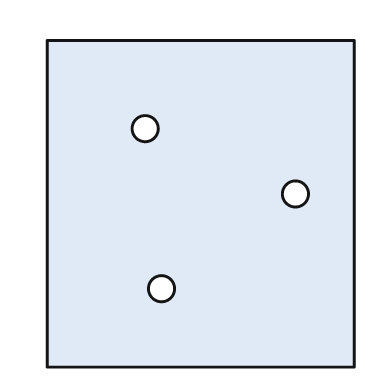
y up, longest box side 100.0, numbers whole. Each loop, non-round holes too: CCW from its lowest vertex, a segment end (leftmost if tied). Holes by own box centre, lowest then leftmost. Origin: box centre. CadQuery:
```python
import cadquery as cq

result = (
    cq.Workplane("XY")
    .moveTo(-47.0, -50.0)
    .lineTo(47.0, -50.0)
    .lineTo(47.0, 50.0)
    .lineTo(-47.0, 50.0)
    .close()
    .moveTo(-12.0, -26.0)
    .circle(4.0)
    .moveTo(29.0, 3.0)
    .circle(4.0)
    .moveTo(-17.0, 23.0)
    .circle(4.0)
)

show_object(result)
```